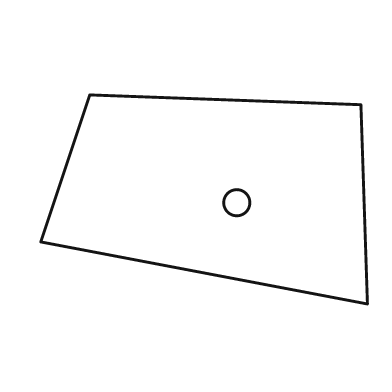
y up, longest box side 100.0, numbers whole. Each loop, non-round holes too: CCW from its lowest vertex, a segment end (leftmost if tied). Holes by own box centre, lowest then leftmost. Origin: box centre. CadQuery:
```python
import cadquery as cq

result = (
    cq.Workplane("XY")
    .moveTo(50.0, -32.0)
    .lineTo(48.0, 29.0)
    .lineTo(-35.0, 32.0)
    .lineTo(-50.0, -13.0)
    .close()
    .moveTo(10.0, -1.0)
    .circle(4.0)
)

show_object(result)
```